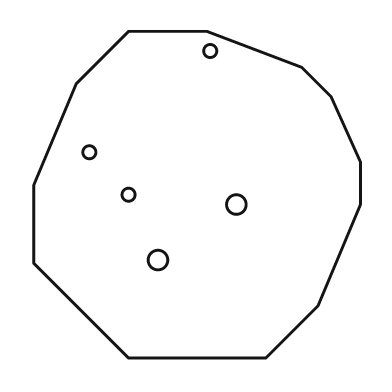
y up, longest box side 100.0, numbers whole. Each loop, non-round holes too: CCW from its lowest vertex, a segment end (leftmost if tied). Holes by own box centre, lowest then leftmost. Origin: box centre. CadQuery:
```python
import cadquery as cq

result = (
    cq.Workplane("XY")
    .moveTo(-21.0, -50.0)
    .lineTo(21.0, -50.0)
    .lineTo(37.0, -34.0)
    .lineTo(50.0, -3.0)
    .lineTo(50.0, 10.0)
    .lineTo(41.0, 30.0)
    .lineTo(32.0, 39.0)
    .lineTo(3.0, 50.0)
    .lineTo(-21.0, 50.0)
    .lineTo(-37.0, 34.0)
    .lineTo(-50.0, 3.0)
    .lineTo(-50.0, -21.0)
    .close()
    .moveTo(-12.0, -20.0)
    .circle(3.0)
    .moveTo(12.0, -3.0)
    .circle(3.0)
    .moveTo(-21.0, 0.0)
    .circle(2.0)
    .moveTo(-33.0, 13.0)
    .circle(2.0)
    .moveTo(4.0, 44.0)
    .circle(2.0)
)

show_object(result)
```